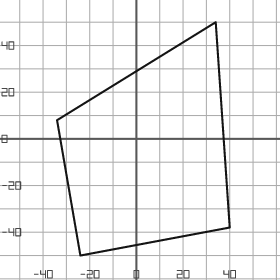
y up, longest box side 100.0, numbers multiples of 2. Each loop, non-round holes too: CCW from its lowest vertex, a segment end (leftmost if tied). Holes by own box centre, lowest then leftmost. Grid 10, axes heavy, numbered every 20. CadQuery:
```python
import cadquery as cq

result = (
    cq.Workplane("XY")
    .moveTo(-24.0, -50.0)
    .lineTo(40.0, -38.0)
    .lineTo(34.0, 50.0)
    .lineTo(-34.0, 8.0)
    .close()
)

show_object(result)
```